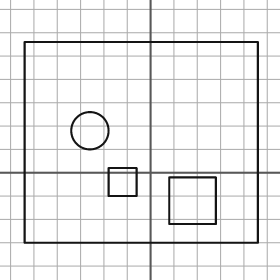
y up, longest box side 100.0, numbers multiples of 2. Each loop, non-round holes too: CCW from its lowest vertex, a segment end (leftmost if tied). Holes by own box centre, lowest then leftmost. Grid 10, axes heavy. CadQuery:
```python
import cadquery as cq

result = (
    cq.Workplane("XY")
    .moveTo(-54.0, -30.0)
    .lineTo(46.0, -30.0)
    .lineTo(46.0, 56.0)
    .lineTo(-54.0, 56.0)
    .close()
    .moveTo(8.0, -22.0)
    .lineTo(28.0, -22.0)
    .lineTo(28.0, -2.0)
    .lineTo(8.0, -2.0)
    .close()
    .moveTo(-18.0, -10.0)
    .lineTo(-6.0, -10.0)
    .lineTo(-6.0, 2.0)
    .lineTo(-18.0, 2.0)
    .close()
    .moveTo(-26.0, 18.0)
    .circle(8.0)
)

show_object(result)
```